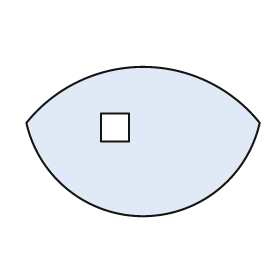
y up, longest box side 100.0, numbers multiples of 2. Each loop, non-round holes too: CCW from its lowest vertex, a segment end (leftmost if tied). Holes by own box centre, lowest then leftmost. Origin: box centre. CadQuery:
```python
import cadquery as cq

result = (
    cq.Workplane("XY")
    .moveTo(-50.0, 8.0)
    .threePointArc((0.0, -32.0), (50.0, 8.0))
    .threePointArc((0.0, 32.0), (-50.0, 8.0))
    .close()
    .moveTo(-18.0, 0.0)
    .lineTo(-6.0, 0.0)
    .lineTo(-6.0, 12.0)
    .lineTo(-18.0, 12.0)
    .close()
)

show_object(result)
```